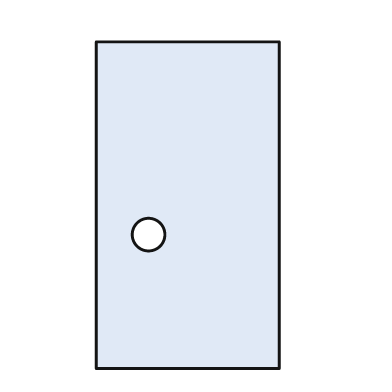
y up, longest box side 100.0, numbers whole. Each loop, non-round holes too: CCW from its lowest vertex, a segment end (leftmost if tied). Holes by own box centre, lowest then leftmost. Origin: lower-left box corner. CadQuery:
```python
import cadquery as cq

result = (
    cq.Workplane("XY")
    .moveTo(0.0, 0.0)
    .lineTo(56.0, 0.0)
    .lineTo(56.0, 100.0)
    .lineTo(0.0, 100.0)
    .close()
    .moveTo(16.0, 41.0)
    .circle(5.0)
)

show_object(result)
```